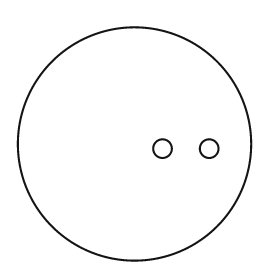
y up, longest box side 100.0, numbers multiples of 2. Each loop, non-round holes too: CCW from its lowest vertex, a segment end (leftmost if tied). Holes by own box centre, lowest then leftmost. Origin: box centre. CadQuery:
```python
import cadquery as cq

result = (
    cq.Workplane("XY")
    .moveTo(0.0, 0.0)
    .circle(50.0)
    .moveTo(12.0, -2.0)
    .circle(4.0)
    .moveTo(32.0, -2.0)
    .circle(4.0)
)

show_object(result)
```